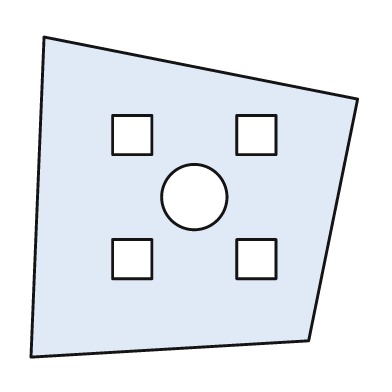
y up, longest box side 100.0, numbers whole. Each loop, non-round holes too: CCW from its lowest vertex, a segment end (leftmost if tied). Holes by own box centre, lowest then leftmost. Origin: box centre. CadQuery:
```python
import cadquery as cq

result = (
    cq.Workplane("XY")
    .moveTo(-50.0, -49.0)
    .lineTo(35.0, -44.0)
    .lineTo(50.0, 30.0)
    .lineTo(-46.0, 49.0)
    .close()
    .moveTo(-25.0, -25.0)
    .lineTo(-13.0, -25.0)
    .lineTo(-13.0, -13.0)
    .lineTo(-25.0, -13.0)
    .close()
    .moveTo(13.0, -25.0)
    .lineTo(25.0, -25.0)
    .lineTo(25.0, -13.0)
    .lineTo(13.0, -13.0)
    .close()
    .moveTo(0.0, 0.0)
    .circle(10.0)
    .moveTo(-25.0, 13.0)
    .lineTo(-13.0, 13.0)
    .lineTo(-13.0, 25.0)
    .lineTo(-25.0, 25.0)
    .close()
    .moveTo(13.0, 13.0)
    .lineTo(25.0, 13.0)
    .lineTo(25.0, 25.0)
    .lineTo(13.0, 25.0)
    .close()
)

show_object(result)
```